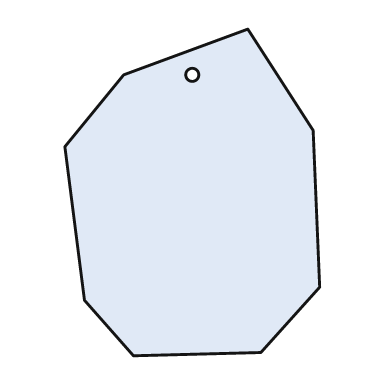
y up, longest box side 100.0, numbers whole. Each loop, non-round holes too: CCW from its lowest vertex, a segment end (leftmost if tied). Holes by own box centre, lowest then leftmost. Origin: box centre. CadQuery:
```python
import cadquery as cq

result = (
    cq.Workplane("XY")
    .moveTo(-18.0, -50.0)
    .lineTo(21.0, -49.0)
    .lineTo(39.0, -29.0)
    .lineTo(37.0, 19.0)
    .lineTo(17.0, 50.0)
    .lineTo(-21.0, 36.0)
    .lineTo(-39.0, 14.0)
    .lineTo(-33.0, -33.0)
    .close()
    .moveTo(0.0, 36.0)
    .circle(2.0)
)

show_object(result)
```